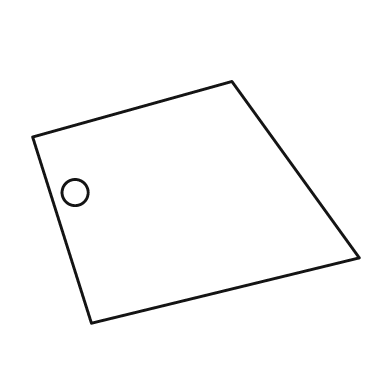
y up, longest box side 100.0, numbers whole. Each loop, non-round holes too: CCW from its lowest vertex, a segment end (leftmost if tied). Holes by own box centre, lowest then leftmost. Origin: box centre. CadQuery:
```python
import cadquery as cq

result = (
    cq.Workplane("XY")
    .moveTo(-32.0, -37.0)
    .lineTo(50.0, -17.0)
    .lineTo(11.0, 37.0)
    .lineTo(-50.0, 20.0)
    .close()
    .moveTo(-37.0, 3.0)
    .circle(4.0)
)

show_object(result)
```